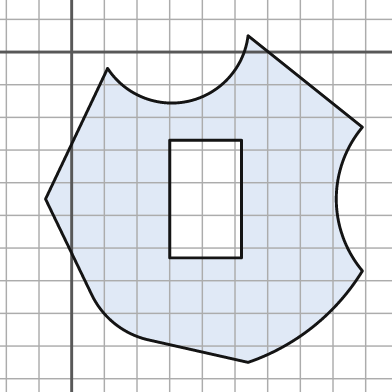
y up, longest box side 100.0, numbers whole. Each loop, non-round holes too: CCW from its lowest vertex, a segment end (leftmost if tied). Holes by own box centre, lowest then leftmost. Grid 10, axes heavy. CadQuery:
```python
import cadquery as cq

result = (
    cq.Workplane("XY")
    .moveTo(54.0, -95.0)
    .threePointArc((74.0, -84.0), (89.0, -67.0))
    .threePointArc((81.0, -45.0), (89.0, -23.0))
    .lineTo(54.0, 5.0)
    .threePointArc((36.0, -15.0), (11.0, -5.0))
    .lineTo(-8.0, -45.0)
    .lineTo(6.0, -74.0)
    .threePointArc((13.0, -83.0), (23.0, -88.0))
    .close()
    .moveTo(30.0, -63.0)
    .lineTo(52.0, -63.0)
    .lineTo(52.0, -27.0)
    .lineTo(30.0, -27.0)
    .close()
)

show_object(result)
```